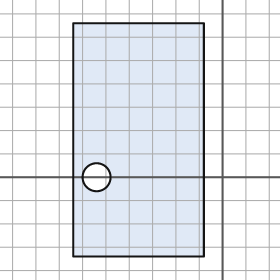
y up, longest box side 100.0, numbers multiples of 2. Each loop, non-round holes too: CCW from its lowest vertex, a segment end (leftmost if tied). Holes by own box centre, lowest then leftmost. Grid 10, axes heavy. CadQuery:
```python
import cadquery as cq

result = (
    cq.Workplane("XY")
    .moveTo(-64.0, -34.0)
    .lineTo(-8.0, -34.0)
    .lineTo(-8.0, 66.0)
    .lineTo(-64.0, 66.0)
    .close()
    .moveTo(-54.0, 0.0)
    .circle(6.0)
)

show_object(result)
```